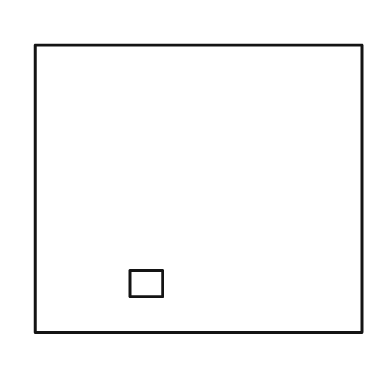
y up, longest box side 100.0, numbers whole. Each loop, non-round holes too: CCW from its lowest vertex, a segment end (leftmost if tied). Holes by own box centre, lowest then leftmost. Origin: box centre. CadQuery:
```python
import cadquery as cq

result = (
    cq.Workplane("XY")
    .moveTo(-50.0, -44.0)
    .lineTo(50.0, -44.0)
    .lineTo(50.0, 44.0)
    .lineTo(-50.0, 44.0)
    .close()
    .moveTo(-21.0, -33.0)
    .lineTo(-11.0, -33.0)
    .lineTo(-11.0, -25.0)
    .lineTo(-21.0, -25.0)
    .close()
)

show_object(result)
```